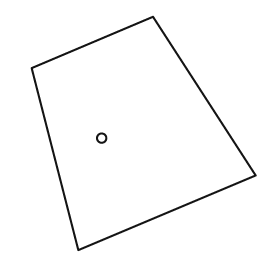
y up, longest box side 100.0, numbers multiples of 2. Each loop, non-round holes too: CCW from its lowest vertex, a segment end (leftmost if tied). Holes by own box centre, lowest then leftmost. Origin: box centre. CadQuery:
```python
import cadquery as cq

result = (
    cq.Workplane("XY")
    .moveTo(-28.0, -50.0)
    .lineTo(48.0, -18.0)
    .lineTo(4.0, 50.0)
    .lineTo(-48.0, 28.0)
    .close()
    .moveTo(-18.0, -2.0)
    .circle(2.0)
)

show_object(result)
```